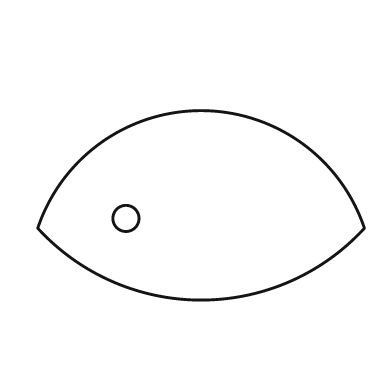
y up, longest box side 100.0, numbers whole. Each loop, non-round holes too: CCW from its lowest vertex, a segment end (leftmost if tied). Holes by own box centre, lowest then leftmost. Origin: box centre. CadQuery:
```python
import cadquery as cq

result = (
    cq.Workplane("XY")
    .moveTo(-50.0, -7.0)
    .threePointArc((0.0, -29.0), (50.0, -7.0))
    .threePointArc((0.0, 29.0), (-50.0, -7.0))
    .close()
    .moveTo(-23.0, -4.0)
    .circle(4.0)
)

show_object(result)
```